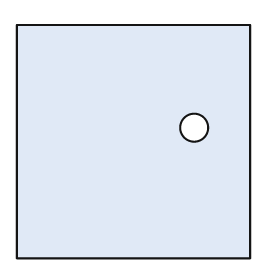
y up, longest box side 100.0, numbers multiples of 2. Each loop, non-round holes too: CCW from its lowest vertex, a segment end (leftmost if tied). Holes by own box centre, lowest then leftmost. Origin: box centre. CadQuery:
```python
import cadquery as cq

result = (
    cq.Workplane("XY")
    .moveTo(-50.0, -50.0)
    .lineTo(50.0, -50.0)
    .lineTo(50.0, 50.0)
    .lineTo(-50.0, 50.0)
    .close()
    .moveTo(26.0, 6.0)
    .circle(6.0)
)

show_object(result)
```